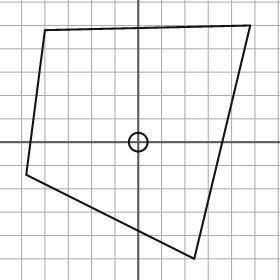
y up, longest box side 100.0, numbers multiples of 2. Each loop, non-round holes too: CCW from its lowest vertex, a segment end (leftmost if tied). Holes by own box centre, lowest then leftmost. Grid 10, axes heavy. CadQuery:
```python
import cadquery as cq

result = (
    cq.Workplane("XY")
    .moveTo(24.0, -50.0)
    .lineTo(48.0, 50.0)
    .lineTo(-40.0, 48.0)
    .lineTo(-48.0, -14.0)
    .close()
    .moveTo(0.0, 0.0)
    .circle(4.0)
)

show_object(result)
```